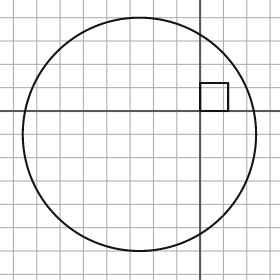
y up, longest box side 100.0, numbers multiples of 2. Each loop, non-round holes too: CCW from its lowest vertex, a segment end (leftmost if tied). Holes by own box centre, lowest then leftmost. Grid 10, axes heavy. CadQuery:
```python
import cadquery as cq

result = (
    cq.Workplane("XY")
    .moveTo(-26.0, -10.0)
    .circle(50.0)
    .moveTo(0.0, 0.0)
    .lineTo(12.0, 0.0)
    .lineTo(12.0, 12.0)
    .lineTo(0.0, 12.0)
    .close()
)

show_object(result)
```